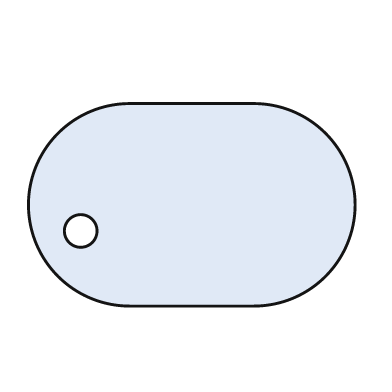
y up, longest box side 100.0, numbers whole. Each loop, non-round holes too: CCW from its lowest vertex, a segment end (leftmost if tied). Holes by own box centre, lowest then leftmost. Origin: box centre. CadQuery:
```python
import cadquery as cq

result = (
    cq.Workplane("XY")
    .moveTo(-19.0, -31.0)
    .lineTo(19.0, -31.0)
    .threePointArc((50.0, 0.0), (19.0, 31.0))
    .lineTo(-19.0, 31.0)
    .threePointArc((-50.0, 0.0), (-19.0, -31.0))
    .close()
    .moveTo(-34.0, -8.0)
    .circle(5.0)
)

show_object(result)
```